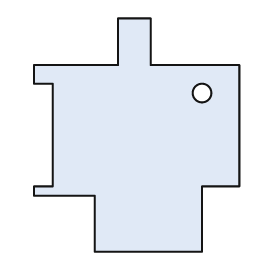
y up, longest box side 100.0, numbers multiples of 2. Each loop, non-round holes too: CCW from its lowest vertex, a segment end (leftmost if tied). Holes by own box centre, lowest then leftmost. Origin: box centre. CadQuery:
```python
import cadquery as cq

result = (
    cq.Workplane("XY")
    .moveTo(-18.0, -50.0)
    .lineTo(28.0, -50.0)
    .lineTo(28.0, -22.0)
    .lineTo(44.0, -22.0)
    .lineTo(44.0, 30.0)
    .lineTo(6.0, 30.0)
    .lineTo(6.0, 50.0)
    .lineTo(-8.0, 50.0)
    .lineTo(-8.0, 30.0)
    .lineTo(-44.0, 30.0)
    .lineTo(-44.0, 22.0)
    .lineTo(-36.0, 22.0)
    .lineTo(-36.0, -22.0)
    .lineTo(-44.0, -22.0)
    .lineTo(-44.0, -26.0)
    .lineTo(-18.0, -26.0)
    .close()
    .moveTo(28.0, 18.0)
    .circle(4.0)
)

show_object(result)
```